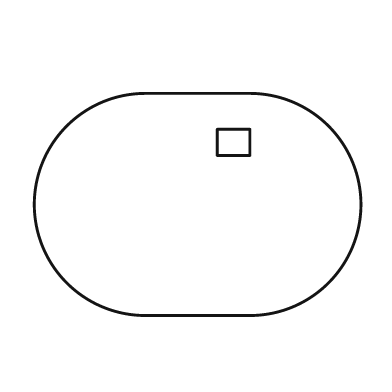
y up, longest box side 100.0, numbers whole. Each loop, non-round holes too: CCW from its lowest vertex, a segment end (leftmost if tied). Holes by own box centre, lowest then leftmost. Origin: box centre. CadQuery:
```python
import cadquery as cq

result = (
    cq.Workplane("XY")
    .moveTo(-16.0, -34.0)
    .lineTo(16.0, -34.0)
    .threePointArc((50.0, 0.0), (16.0, 34.0))
    .lineTo(-16.0, 34.0)
    .threePointArc((-50.0, 0.0), (-16.0, -34.0))
    .close()
    .moveTo(6.0, 15.0)
    .lineTo(16.0, 15.0)
    .lineTo(16.0, 23.0)
    .lineTo(6.0, 23.0)
    .close()
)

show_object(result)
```